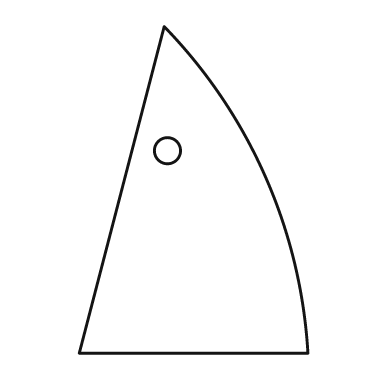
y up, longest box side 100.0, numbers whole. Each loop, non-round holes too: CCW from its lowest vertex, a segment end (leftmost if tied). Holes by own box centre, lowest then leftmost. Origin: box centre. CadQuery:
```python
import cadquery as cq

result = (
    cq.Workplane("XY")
    .moveTo(-35.0, -50.0)
    .lineTo(35.0, -50.0)
    .threePointArc((22.0, 4.0), (-9.0, 50.0))
    .close()
    .moveTo(-8.0, 12.0)
    .circle(4.0)
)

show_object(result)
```